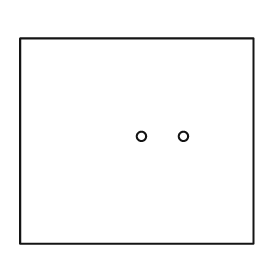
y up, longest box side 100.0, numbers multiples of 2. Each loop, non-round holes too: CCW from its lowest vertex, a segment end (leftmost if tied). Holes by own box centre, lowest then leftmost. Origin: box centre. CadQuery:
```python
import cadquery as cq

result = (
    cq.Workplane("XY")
    .moveTo(-50.0, -44.0)
    .lineTo(50.0, -44.0)
    .lineTo(50.0, 44.0)
    .lineTo(-50.0, 44.0)
    .close()
    .moveTo(2.0, 2.0)
    .circle(2.0)
    .moveTo(20.0, 2.0)
    .circle(2.0)
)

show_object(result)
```